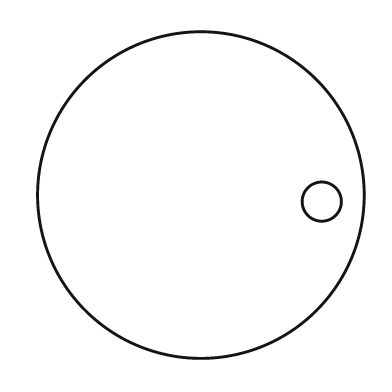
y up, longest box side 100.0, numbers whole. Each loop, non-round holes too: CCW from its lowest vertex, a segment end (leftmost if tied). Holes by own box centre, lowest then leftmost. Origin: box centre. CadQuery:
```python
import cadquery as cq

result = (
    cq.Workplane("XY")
    .moveTo(0.0, 0.0)
    .circle(50.0)
    .moveTo(37.0, -2.0)
    .circle(6.0)
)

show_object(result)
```